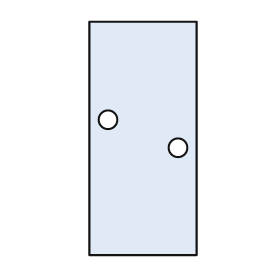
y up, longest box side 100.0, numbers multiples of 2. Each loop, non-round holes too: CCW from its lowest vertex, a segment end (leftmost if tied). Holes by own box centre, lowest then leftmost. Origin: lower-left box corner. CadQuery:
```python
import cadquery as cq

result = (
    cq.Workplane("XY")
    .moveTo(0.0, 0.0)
    .lineTo(46.0, 0.0)
    .lineTo(46.0, 100.0)
    .lineTo(0.0, 100.0)
    .close()
    .moveTo(38.0, 46.0)
    .circle(4.0)
    .moveTo(8.0, 58.0)
    .circle(4.0)
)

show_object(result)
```